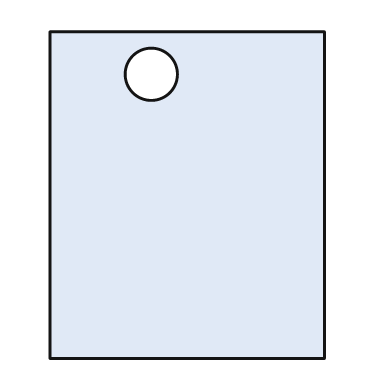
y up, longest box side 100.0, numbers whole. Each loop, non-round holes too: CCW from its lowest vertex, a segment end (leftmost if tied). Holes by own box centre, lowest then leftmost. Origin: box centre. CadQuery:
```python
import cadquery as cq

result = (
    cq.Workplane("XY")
    .moveTo(-42.0, -50.0)
    .lineTo(42.0, -50.0)
    .lineTo(42.0, 50.0)
    .lineTo(-42.0, 50.0)
    .close()
    .moveTo(-11.0, 37.0)
    .circle(8.0)
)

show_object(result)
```